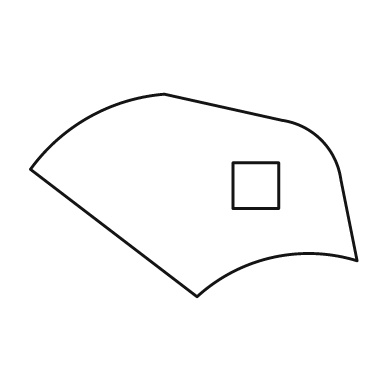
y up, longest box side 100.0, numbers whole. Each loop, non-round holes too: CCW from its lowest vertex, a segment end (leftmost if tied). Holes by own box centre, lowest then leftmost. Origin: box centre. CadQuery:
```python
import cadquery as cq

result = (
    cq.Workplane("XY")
    .moveTo(1.0, -31.0)
    .threePointArc((24.0, -19.0), (50.0, -20.0))
    .lineTo(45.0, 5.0)
    .threePointArc((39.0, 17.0), (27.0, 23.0))
    .lineTo(-9.0, 31.0)
    .threePointArc((-32.0, 24.0), (-50.0, 8.0))
    .close()
    .moveTo(12.0, -4.0)
    .lineTo(26.0, -4.0)
    .lineTo(26.0, 10.0)
    .lineTo(12.0, 10.0)
    .close()
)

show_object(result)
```